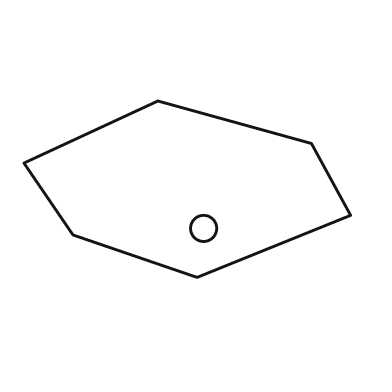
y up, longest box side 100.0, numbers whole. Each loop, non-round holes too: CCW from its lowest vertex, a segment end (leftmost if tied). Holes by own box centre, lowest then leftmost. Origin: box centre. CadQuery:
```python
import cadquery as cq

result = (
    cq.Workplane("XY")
    .moveTo(3.0, -27.0)
    .lineTo(50.0, -8.0)
    .lineTo(38.0, 14.0)
    .lineTo(-9.0, 27.0)
    .lineTo(-50.0, 8.0)
    .lineTo(-35.0, -14.0)
    .close()
    .moveTo(5.0, -12.0)
    .circle(4.0)
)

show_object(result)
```